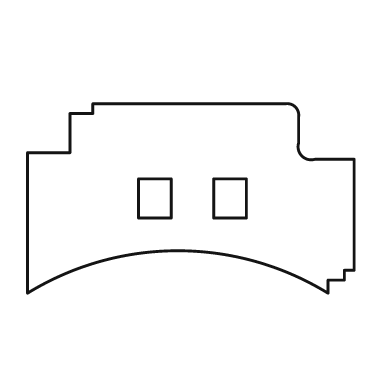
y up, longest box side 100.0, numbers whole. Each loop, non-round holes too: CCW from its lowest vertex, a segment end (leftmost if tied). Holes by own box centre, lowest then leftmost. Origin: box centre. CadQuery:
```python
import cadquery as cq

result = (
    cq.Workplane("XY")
    .moveTo(-50.0, -29.0)
    .threePointArc((-4.0, -16.0), (42.0, -29.0))
    .lineTo(42.0, -25.0)
    .lineTo(47.0, -25.0)
    .lineTo(47.0, -22.0)
    .lineTo(50.0, -22.0)
    .lineTo(50.0, 12.0)
    .lineTo(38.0, 12.0)
    .threePointArc((34.0, 13.0), (33.0, 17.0))
    .lineTo(33.0, 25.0)
    .threePointArc((32.0, 28.0), (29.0, 29.0))
    .lineTo(-30.0, 29.0)
    .lineTo(-30.0, 26.0)
    .lineTo(-37.0, 26.0)
    .lineTo(-37.0, 14.0)
    .lineTo(-50.0, 14.0)
    .close()
    .moveTo(-16.0, -6.0)
    .lineTo(-6.0, -6.0)
    .lineTo(-6.0, 6.0)
    .lineTo(-16.0, 6.0)
    .close()
    .moveTo(7.0, -6.0)
    .lineTo(17.0, -6.0)
    .lineTo(17.0, 6.0)
    .lineTo(7.0, 6.0)
    .close()
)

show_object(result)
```